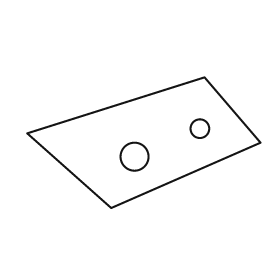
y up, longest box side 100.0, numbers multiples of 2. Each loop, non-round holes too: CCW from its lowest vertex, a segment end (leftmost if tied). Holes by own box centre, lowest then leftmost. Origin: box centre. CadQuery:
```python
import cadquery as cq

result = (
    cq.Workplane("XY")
    .moveTo(-14.0, -28.0)
    .lineTo(50.0, 0.0)
    .lineTo(26.0, 28.0)
    .lineTo(-50.0, 4.0)
    .close()
    .moveTo(-4.0, -6.0)
    .circle(6.0)
    .moveTo(24.0, 6.0)
    .circle(4.0)
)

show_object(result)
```